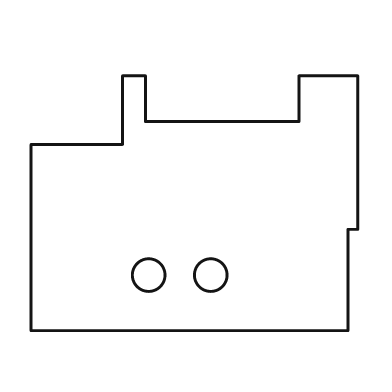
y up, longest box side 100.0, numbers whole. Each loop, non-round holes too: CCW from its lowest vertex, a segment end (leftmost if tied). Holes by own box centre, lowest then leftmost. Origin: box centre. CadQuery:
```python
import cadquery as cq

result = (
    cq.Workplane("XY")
    .moveTo(-50.0, -39.0)
    .lineTo(47.0, -39.0)
    .lineTo(47.0, -8.0)
    .lineTo(50.0, -8.0)
    .lineTo(50.0, 39.0)
    .lineTo(32.0, 39.0)
    .lineTo(32.0, 25.0)
    .lineTo(-15.0, 25.0)
    .lineTo(-15.0, 39.0)
    .lineTo(-22.0, 39.0)
    .lineTo(-22.0, 18.0)
    .lineTo(-50.0, 18.0)
    .close()
    .moveTo(-14.0, -22.0)
    .circle(5.0)
    .moveTo(5.0, -22.0)
    .circle(5.0)
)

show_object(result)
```